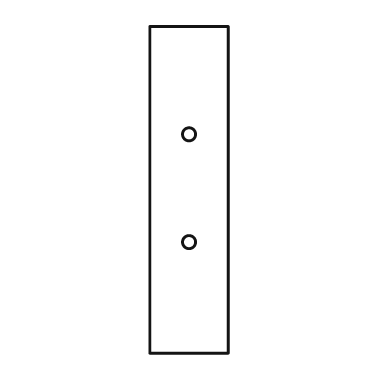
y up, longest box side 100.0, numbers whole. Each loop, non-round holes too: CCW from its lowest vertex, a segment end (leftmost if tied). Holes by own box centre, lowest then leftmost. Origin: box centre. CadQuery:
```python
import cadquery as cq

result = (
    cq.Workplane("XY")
    .moveTo(-12.0, -50.0)
    .lineTo(12.0, -50.0)
    .lineTo(12.0, 50.0)
    .lineTo(-12.0, 50.0)
    .close()
    .moveTo(0.0, -16.0)
    .circle(2.0)
    .moveTo(0.0, 17.0)
    .circle(2.0)
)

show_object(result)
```